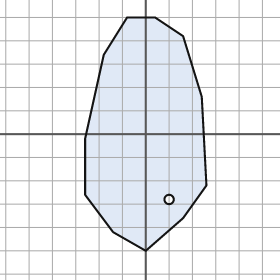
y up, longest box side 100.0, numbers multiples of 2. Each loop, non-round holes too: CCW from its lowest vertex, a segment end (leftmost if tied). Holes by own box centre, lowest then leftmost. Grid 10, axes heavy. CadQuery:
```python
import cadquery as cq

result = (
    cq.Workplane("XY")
    .moveTo(0.0, -50.0)
    .lineTo(16.0, -36.0)
    .lineTo(26.0, -22.0)
    .lineTo(24.0, 16.0)
    .lineTo(16.0, 42.0)
    .lineTo(4.0, 50.0)
    .lineTo(-8.0, 50.0)
    .lineTo(-18.0, 34.0)
    .lineTo(-26.0, -2.0)
    .lineTo(-26.0, -26.0)
    .lineTo(-14.0, -42.0)
    .close()
    .moveTo(10.0, -28.0)
    .circle(2.0)
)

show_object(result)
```